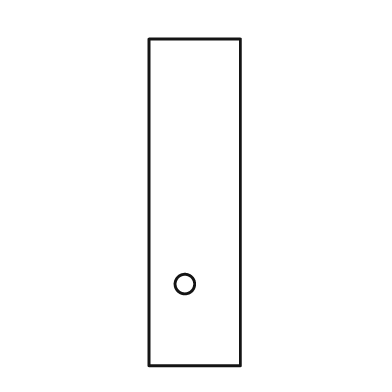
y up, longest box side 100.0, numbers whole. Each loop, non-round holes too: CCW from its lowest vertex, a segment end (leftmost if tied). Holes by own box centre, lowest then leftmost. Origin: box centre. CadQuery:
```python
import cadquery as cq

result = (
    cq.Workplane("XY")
    .moveTo(-14.0, -50.0)
    .lineTo(14.0, -50.0)
    .lineTo(14.0, 50.0)
    .lineTo(-14.0, 50.0)
    .close()
    .moveTo(-3.0, -25.0)
    .circle(3.0)
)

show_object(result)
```